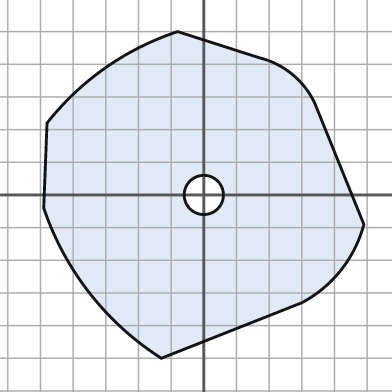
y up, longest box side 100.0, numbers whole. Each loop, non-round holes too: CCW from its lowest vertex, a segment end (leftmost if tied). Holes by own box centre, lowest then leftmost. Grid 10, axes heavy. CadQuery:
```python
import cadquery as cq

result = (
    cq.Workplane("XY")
    .moveTo(-13.0, -50.0)
    .lineTo(30.0, -33.0)
    .threePointArc((42.0, -23.0), (49.0, -9.0))
    .lineTo(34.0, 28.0)
    .threePointArc((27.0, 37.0), (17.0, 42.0))
    .lineTo(-8.0, 50.0)
    .threePointArc((-30.0, 39.0), (-48.0, 22.0))
    .lineTo(-49.0, -4.0)
    .threePointArc((-35.0, -30.0), (-13.0, -50.0))
    .close()
    .moveTo(0.0, 0.0)
    .circle(6.0)
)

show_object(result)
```